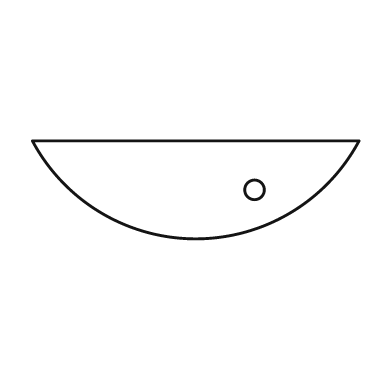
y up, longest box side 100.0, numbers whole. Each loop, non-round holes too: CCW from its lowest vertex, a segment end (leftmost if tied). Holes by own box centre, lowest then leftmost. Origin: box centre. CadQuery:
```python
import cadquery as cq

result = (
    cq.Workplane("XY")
    .moveTo(-50.0, 15.0)
    .threePointArc((0.0, -15.0), (50.0, 15.0))
    .close()
    .moveTo(18.0, 0.0)
    .circle(3.0)
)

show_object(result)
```